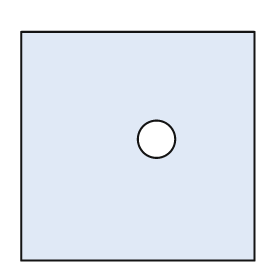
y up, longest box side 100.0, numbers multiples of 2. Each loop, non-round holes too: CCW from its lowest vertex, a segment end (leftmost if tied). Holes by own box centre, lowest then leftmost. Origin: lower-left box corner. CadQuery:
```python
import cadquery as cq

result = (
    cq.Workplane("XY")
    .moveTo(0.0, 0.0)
    .lineTo(100.0, 0.0)
    .lineTo(100.0, 98.0)
    .lineTo(0.0, 98.0)
    .close()
    .moveTo(58.0, 52.0)
    .circle(8.0)
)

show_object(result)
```